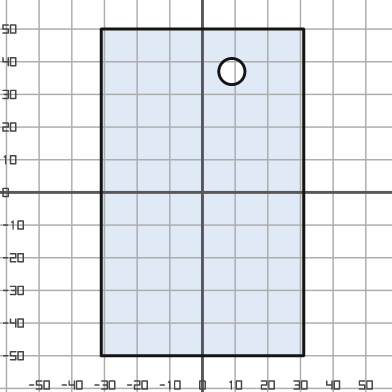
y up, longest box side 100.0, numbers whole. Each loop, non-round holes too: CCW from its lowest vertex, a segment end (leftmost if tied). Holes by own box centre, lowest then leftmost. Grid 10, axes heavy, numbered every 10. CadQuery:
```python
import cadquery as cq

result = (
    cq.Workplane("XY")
    .moveTo(-31.0, -50.0)
    .lineTo(31.0, -50.0)
    .lineTo(31.0, 50.0)
    .lineTo(-31.0, 50.0)
    .close()
    .moveTo(9.0, 37.0)
    .circle(4.0)
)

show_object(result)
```